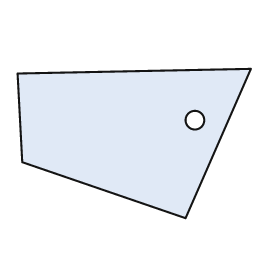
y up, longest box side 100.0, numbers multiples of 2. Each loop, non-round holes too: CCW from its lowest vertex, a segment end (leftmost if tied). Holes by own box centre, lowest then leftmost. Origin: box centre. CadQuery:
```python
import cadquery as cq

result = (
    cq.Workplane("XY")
    .moveTo(22.0, -32.0)
    .lineTo(50.0, 32.0)
    .lineTo(-50.0, 30.0)
    .lineTo(-48.0, -8.0)
    .close()
    .moveTo(26.0, 10.0)
    .circle(4.0)
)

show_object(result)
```